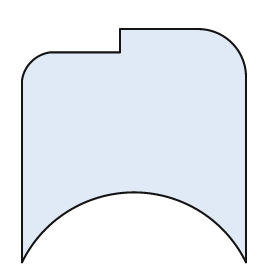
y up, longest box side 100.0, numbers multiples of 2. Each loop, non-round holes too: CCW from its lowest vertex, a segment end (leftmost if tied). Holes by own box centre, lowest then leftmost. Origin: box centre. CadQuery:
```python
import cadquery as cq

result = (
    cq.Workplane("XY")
    .moveTo(-48.0, -50.0)
    .threePointArc((0.0, -20.0), (48.0, -50.0))
    .lineTo(48.0, 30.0)
    .threePointArc((42.0, 44.0), (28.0, 50.0))
    .lineTo(-6.0, 50.0)
    .lineTo(-6.0, 40.0)
    .lineTo(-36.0, 40.0)
    .threePointArc((-44.0, 36.0), (-48.0, 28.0))
    .close()
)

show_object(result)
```